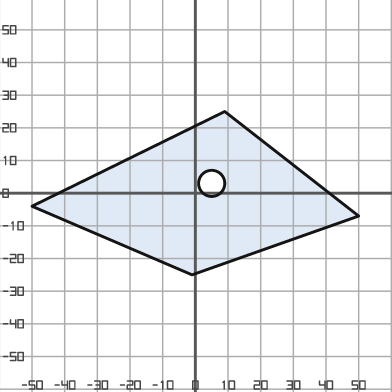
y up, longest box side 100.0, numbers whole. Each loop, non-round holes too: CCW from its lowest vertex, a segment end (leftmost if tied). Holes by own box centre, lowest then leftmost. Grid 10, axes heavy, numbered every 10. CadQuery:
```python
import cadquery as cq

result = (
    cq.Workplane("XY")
    .moveTo(-1.0, -25.0)
    .lineTo(50.0, -7.0)
    .lineTo(9.0, 25.0)
    .lineTo(-50.0, -4.0)
    .close()
    .moveTo(5.0, 3.0)
    .circle(4.0)
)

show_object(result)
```